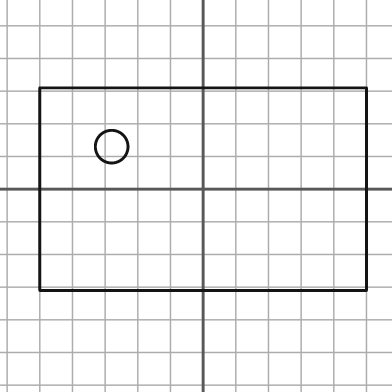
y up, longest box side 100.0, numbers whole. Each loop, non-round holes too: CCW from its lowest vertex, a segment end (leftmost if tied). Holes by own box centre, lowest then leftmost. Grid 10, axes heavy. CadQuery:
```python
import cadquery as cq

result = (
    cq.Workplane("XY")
    .moveTo(-50.0, -31.0)
    .lineTo(50.0, -31.0)
    .lineTo(50.0, 31.0)
    .lineTo(-50.0, 31.0)
    .close()
    .moveTo(-28.0, 13.0)
    .circle(5.0)
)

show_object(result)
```